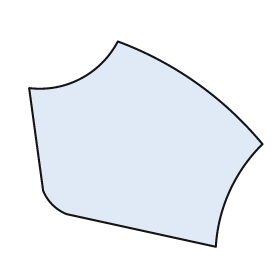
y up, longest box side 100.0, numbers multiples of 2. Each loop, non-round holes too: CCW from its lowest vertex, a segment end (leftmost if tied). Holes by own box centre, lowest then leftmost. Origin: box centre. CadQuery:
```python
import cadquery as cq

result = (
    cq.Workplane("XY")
    .moveTo(30.0, -44.0)
    .threePointArc((36.0, -20.0), (50.0, 0.0))
    .threePointArc((22.0, 26.0), (-12.0, 44.0))
    .threePointArc((-28.0, 28.0), (-50.0, 24.0))
    .lineTo(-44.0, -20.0)
    .threePointArc((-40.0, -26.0), (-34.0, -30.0))
    .close()
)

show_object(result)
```